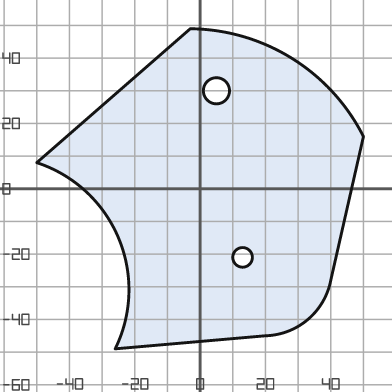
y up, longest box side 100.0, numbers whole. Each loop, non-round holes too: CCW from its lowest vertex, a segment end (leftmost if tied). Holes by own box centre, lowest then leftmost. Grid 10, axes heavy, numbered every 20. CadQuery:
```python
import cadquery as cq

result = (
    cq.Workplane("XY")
    .moveTo(-26.0, -49.0)
    .lineTo(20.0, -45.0)
    .threePointArc((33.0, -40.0), (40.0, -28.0))
    .lineTo(50.0, 16.0)
    .threePointArc((28.0, 40.0), (-3.0, 49.0))
    .lineTo(-50.0, 8.0)
    .threePointArc((-25.0, -15.0), (-26.0, -49.0))
    .close()
    .moveTo(13.0, -21.0)
    .circle(3.0)
    .moveTo(5.0, 30.0)
    .circle(4.0)
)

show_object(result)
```